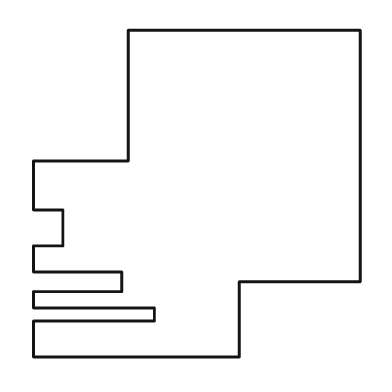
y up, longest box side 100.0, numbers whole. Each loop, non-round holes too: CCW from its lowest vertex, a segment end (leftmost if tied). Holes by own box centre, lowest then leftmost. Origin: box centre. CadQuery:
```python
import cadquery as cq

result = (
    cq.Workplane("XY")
    .moveTo(-50.0, -50.0)
    .lineTo(13.0, -50.0)
    .lineTo(13.0, -27.0)
    .lineTo(50.0, -27.0)
    .lineTo(50.0, 50.0)
    .lineTo(-21.0, 50.0)
    .lineTo(-21.0, 10.0)
    .lineTo(-50.0, 10.0)
    .lineTo(-50.0, -5.0)
    .lineTo(-41.0, -5.0)
    .lineTo(-41.0, -16.0)
    .lineTo(-50.0, -16.0)
    .lineTo(-50.0, -24.0)
    .lineTo(-23.0, -24.0)
    .lineTo(-23.0, -30.0)
    .lineTo(-50.0, -30.0)
    .lineTo(-50.0, -35.0)
    .lineTo(-13.0, -35.0)
    .lineTo(-13.0, -39.0)
    .lineTo(-50.0, -39.0)
    .close()
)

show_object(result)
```